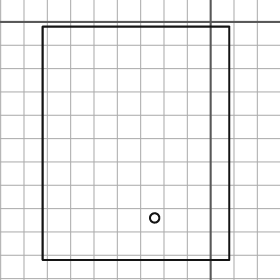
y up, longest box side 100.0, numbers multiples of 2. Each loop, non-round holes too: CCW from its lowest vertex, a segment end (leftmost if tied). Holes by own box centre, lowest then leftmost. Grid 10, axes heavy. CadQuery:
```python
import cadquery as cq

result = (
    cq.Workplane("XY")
    .moveTo(-72.0, -102.0)
    .lineTo(8.0, -102.0)
    .lineTo(8.0, -2.0)
    .lineTo(-72.0, -2.0)
    .close()
    .moveTo(-24.0, -84.0)
    .circle(2.0)
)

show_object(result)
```